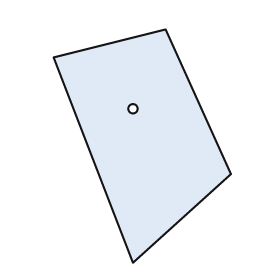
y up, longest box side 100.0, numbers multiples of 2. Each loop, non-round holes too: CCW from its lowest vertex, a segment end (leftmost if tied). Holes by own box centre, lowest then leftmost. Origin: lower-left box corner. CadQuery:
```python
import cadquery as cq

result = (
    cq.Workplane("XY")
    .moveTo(34.0, 0.0)
    .lineTo(76.0, 38.0)
    .lineTo(48.0, 100.0)
    .lineTo(0.0, 88.0)
    .close()
    .moveTo(34.0, 66.0)
    .circle(2.0)
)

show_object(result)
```